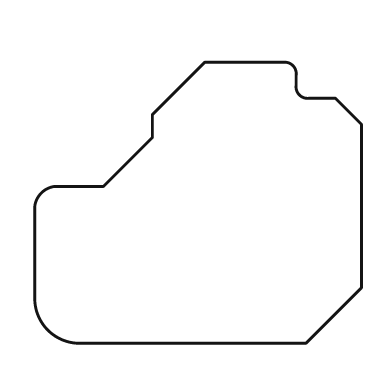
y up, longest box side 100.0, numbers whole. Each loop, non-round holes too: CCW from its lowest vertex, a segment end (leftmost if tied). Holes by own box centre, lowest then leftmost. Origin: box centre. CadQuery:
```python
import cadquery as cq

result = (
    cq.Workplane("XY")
    .moveTo(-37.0, -43.0)
    .lineTo(33.0, -43.0)
    .lineTo(50.0, -26.0)
    .lineTo(50.0, 24.0)
    .lineTo(42.0, 32.0)
    .lineTo(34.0, 32.0)
    .threePointArc((31.0, 33.0), (30.0, 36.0))
    .lineTo(30.0, 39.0)
    .threePointArc((29.0, 42.0), (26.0, 43.0))
    .lineTo(2.0, 43.0)
    .lineTo(-14.0, 27.0)
    .lineTo(-14.0, 20.0)
    .lineTo(-29.0, 5.0)
    .lineTo(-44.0, 5.0)
    .threePointArc((-48.0, 3.0), (-50.0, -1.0))
    .lineTo(-50.0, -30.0)
    .threePointArc((-46.0, -39.0), (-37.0, -43.0))
    .close()
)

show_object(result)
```